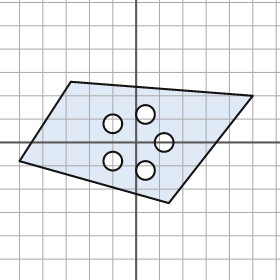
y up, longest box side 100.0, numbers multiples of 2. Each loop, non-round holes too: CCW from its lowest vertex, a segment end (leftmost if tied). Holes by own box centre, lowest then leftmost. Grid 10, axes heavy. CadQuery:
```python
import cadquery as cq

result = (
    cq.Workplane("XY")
    .moveTo(14.0, -26.0)
    .lineTo(50.0, 20.0)
    .lineTo(-28.0, 26.0)
    .lineTo(-50.0, -8.0)
    .close()
    .moveTo(4.0, -12.0)
    .circle(4.0)
    .moveTo(-10.0, -8.0)
    .circle(4.0)
    .moveTo(12.0, 0.0)
    .circle(4.0)
    .moveTo(-10.0, 8.0)
    .circle(4.0)
    .moveTo(4.0, 12.0)
    .circle(4.0)
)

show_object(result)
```